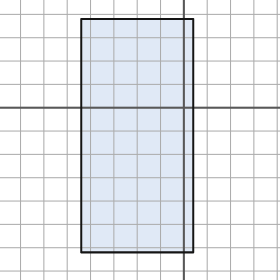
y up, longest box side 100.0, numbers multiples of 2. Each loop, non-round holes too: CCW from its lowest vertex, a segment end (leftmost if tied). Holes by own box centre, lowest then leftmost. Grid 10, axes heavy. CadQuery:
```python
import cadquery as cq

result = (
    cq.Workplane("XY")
    .moveTo(-44.0, -62.0)
    .lineTo(4.0, -62.0)
    .lineTo(4.0, 38.0)
    .lineTo(-44.0, 38.0)
    .close()
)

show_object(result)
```